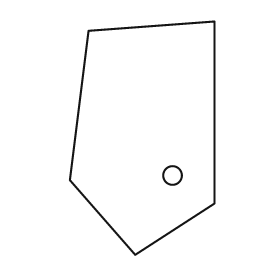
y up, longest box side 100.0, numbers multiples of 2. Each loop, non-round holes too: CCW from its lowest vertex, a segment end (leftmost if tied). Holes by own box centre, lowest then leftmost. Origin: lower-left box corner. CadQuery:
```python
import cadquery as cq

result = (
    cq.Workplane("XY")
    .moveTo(28.0, 0.0)
    .lineTo(62.0, 22.0)
    .lineTo(62.0, 100.0)
    .lineTo(8.0, 96.0)
    .lineTo(0.0, 32.0)
    .close()
    .moveTo(44.0, 34.0)
    .circle(4.0)
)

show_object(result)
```